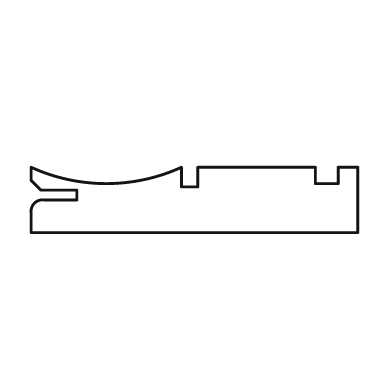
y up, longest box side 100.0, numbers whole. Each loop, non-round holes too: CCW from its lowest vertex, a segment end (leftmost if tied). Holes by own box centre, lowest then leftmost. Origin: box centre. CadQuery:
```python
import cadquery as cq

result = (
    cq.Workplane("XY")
    .moveTo(-50.0, -10.0)
    .lineTo(50.0, -10.0)
    .lineTo(50.0, 10.0)
    .lineTo(44.0, 10.0)
    .lineTo(44.0, 5.0)
    .lineTo(37.0, 5.0)
    .lineTo(37.0, 10.0)
    .lineTo(1.0, 10.0)
    .lineTo(1.0, 4.0)
    .lineTo(-4.0, 4.0)
    .lineTo(-4.0, 10.0)
    .threePointArc((-27.0, 5.0), (-50.0, 10.0))
    .lineTo(-50.0, 6.0)
    .lineTo(-47.0, 3.0)
    .lineTo(-36.0, 3.0)
    .lineTo(-36.0, 0.0)
    .lineTo(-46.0, 0.0)
    .threePointArc((-49.0, -1.0), (-50.0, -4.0))
    .close()
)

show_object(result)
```